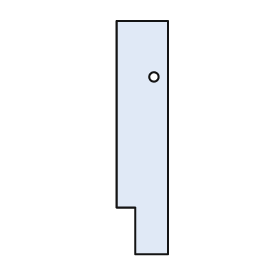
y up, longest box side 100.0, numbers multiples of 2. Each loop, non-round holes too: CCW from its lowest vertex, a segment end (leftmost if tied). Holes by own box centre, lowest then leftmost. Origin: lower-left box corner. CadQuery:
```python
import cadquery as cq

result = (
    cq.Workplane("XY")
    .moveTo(8.0, 0.0)
    .lineTo(22.0, 0.0)
    .lineTo(22.0, 100.0)
    .lineTo(0.0, 100.0)
    .lineTo(0.0, 20.0)
    .lineTo(8.0, 20.0)
    .close()
    .moveTo(16.0, 76.0)
    .circle(2.0)
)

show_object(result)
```